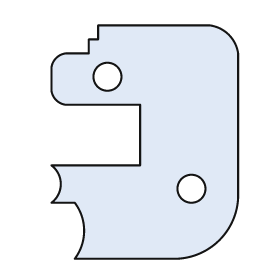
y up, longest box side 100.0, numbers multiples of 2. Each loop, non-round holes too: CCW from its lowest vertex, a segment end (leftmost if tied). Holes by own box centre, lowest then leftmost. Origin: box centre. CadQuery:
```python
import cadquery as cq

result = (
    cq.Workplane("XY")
    .moveTo(-30.0, -50.0)
    .lineTo(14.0, -50.0)
    .threePointArc((32.0, -42.0), (40.0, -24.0))
    .lineTo(40.0, 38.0)
    .threePointArc((36.0, 46.0), (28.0, 50.0))
    .lineTo(-20.0, 50.0)
    .lineTo(-20.0, 44.0)
    .lineTo(-24.0, 44.0)
    .lineTo(-24.0, 38.0)
    .lineTo(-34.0, 38.0)
    .threePointArc((-38.0, 36.0), (-40.0, 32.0))
    .lineTo(-40.0, 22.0)
    .threePointArc((-38.0, 18.0), (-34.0, 16.0))
    .lineTo(-2.0, 16.0)
    .lineTo(-2.0, -10.0)
    .lineTo(-40.0, -10.0)
    .threePointArc((-36.0, -18.0), (-40.0, -26.0))
    .lineTo(-30.0, -26.0)
    .threePointArc((-26.0, -38.0), (-30.0, -50.0))
    .close()
    .moveTo(20.0, -20.0)
    .circle(6.0)
    .moveTo(-16.0, 28.0)
    .circle(6.0)
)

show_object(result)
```